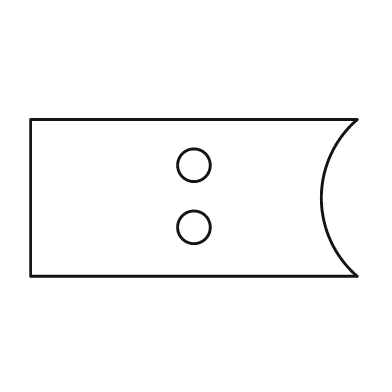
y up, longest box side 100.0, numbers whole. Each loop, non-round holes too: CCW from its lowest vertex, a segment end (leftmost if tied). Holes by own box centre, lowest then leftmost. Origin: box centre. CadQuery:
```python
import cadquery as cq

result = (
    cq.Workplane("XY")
    .moveTo(-50.0, -24.0)
    .lineTo(50.0, -24.0)
    .threePointArc((39.0, 0.0), (50.0, 24.0))
    .lineTo(-50.0, 24.0)
    .close()
    .moveTo(0.0, -9.0)
    .circle(5.0)
    .moveTo(0.0, 10.0)
    .circle(5.0)
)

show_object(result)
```